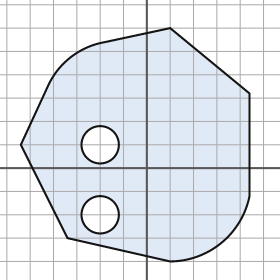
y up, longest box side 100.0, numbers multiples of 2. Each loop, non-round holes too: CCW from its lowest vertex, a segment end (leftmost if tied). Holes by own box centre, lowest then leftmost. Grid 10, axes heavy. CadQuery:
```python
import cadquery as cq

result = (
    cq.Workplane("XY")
    .moveTo(10.0, -40.0)
    .threePointArc((32.0, -32.0), (44.0, -12.0))
    .lineTo(44.0, 32.0)
    .lineTo(10.0, 60.0)
    .lineTo(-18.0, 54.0)
    .threePointArc((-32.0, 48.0), (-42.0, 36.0))
    .lineTo(-54.0, 10.0)
    .lineTo(-34.0, -30.0)
    .close()
    .moveTo(-20.0, -20.0)
    .circle(8.0)
    .moveTo(-20.0, 10.0)
    .circle(8.0)
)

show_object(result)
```